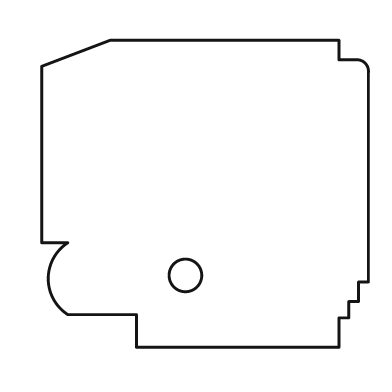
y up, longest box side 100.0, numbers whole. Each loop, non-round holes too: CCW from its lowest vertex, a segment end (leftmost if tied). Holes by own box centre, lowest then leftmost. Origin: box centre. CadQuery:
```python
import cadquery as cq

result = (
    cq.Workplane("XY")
    .moveTo(-21.0, -47.0)
    .lineTo(41.0, -47.0)
    .lineTo(41.0, -38.0)
    .lineTo(44.0, -38.0)
    .lineTo(44.0, -33.0)
    .lineTo(47.0, -33.0)
    .lineTo(47.0, -27.0)
    .lineTo(50.0, -27.0)
    .lineTo(50.0, 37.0)
    .threePointArc((49.0, 40.0), (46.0, 41.0))
    .lineTo(41.0, 41.0)
    .lineTo(41.0, 47.0)
    .lineTo(-29.0, 47.0)
    .lineTo(-50.0, 39.0)
    .lineTo(-50.0, -15.0)
    .lineTo(-42.0, -15.0)
    .threePointArc((-48.0, -26.0), (-42.0, -37.0))
    .lineTo(-21.0, -37.0)
    .close()
    .moveTo(-6.0, -25.0)
    .circle(5.0)
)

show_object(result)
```